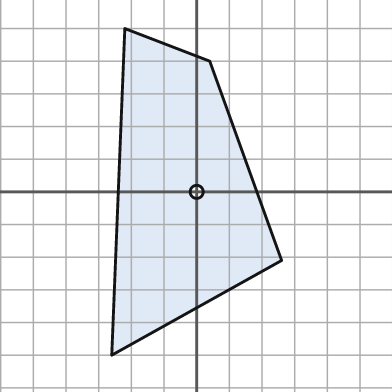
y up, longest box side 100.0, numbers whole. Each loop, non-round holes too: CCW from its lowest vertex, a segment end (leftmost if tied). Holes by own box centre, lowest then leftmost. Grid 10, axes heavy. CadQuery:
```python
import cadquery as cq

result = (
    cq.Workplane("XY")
    .moveTo(-26.0, -50.0)
    .lineTo(26.0, -21.0)
    .lineTo(4.0, 40.0)
    .lineTo(-22.0, 50.0)
    .close()
    .moveTo(0.0, 0.0)
    .circle(2.0)
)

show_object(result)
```